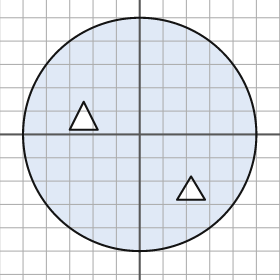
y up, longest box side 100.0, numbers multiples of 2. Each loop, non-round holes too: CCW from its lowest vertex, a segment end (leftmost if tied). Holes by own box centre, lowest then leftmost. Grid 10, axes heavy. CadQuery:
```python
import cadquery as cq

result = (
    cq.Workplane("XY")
    .moveTo(0.0, 0.0)
    .circle(50.0)
    .moveTo(16.0, -28.0)
    .lineTo(28.0, -28.0)
    .lineTo(22.0, -18.0)
    .close()
    .moveTo(-30.0, 2.0)
    .lineTo(-18.0, 2.0)
    .lineTo(-24.0, 14.0)
    .close()
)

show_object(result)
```